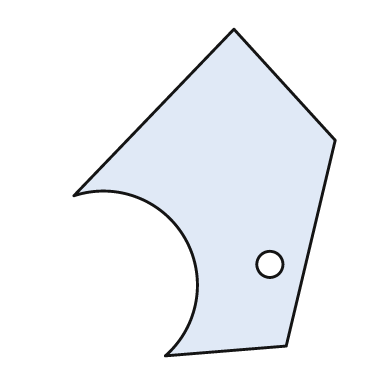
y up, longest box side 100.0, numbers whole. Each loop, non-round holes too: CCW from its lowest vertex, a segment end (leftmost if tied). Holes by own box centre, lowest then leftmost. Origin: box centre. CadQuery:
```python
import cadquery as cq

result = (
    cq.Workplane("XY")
    .moveTo(-12.0, -50.0)
    .lineTo(25.0, -47.0)
    .lineTo(40.0, 16.0)
    .lineTo(9.0, 50.0)
    .lineTo(-40.0, -1.0)
    .threePointArc((-6.0, -14.0), (-12.0, -50.0))
    .close()
    .moveTo(20.0, -22.0)
    .circle(4.0)
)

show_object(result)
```